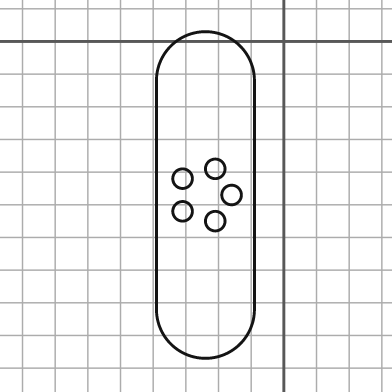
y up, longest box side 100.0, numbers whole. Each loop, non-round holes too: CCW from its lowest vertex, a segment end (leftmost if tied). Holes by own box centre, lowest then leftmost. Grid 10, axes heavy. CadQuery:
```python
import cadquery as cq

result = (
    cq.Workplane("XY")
    .moveTo(-39.0, -82.0)
    .threePointArc((-24.0, -97.0), (-9.0, -82.0))
    .lineTo(-9.0, -12.0)
    .threePointArc((-24.0, 3.0), (-39.0, -12.0))
    .close()
    .moveTo(-21.0, -55.0)
    .circle(3.0)
    .moveTo(-31.0, -52.0)
    .circle(3.0)
    .moveTo(-16.0, -47.0)
    .circle(3.0)
    .moveTo(-31.0, -42.0)
    .circle(3.0)
    .moveTo(-21.0, -39.0)
    .circle(3.0)
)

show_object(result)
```